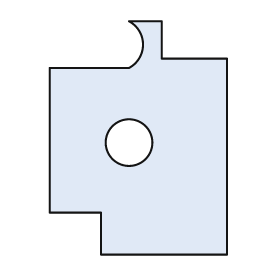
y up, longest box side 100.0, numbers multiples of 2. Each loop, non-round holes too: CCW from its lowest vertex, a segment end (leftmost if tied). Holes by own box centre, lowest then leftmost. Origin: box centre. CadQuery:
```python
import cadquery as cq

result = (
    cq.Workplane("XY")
    .moveTo(-16.0, -50.0)
    .lineTo(38.0, -50.0)
    .lineTo(38.0, 34.0)
    .lineTo(10.0, 34.0)
    .lineTo(10.0, 50.0)
    .lineTo(-4.0, 50.0)
    .threePointArc((2.0, 40.0), (-4.0, 30.0))
    .lineTo(-38.0, 30.0)
    .lineTo(-38.0, -32.0)
    .lineTo(-16.0, -32.0)
    .close()
    .moveTo(-4.0, -2.0)
    .circle(10.0)
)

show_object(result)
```